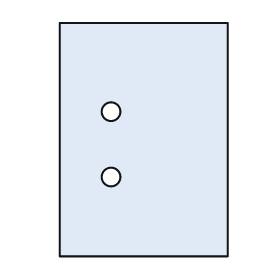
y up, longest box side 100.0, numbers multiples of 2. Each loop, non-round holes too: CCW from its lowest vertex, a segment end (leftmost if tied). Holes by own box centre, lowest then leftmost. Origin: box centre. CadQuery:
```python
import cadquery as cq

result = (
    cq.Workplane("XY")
    .moveTo(-36.0, -50.0)
    .lineTo(36.0, -50.0)
    .lineTo(36.0, 50.0)
    .lineTo(-36.0, 50.0)
    .close()
    .moveTo(-14.0, -16.0)
    .circle(4.0)
    .moveTo(-14.0, 12.0)
    .circle(4.0)
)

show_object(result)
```